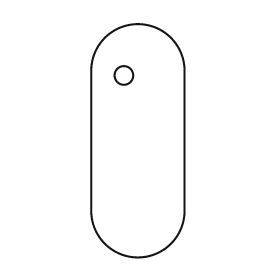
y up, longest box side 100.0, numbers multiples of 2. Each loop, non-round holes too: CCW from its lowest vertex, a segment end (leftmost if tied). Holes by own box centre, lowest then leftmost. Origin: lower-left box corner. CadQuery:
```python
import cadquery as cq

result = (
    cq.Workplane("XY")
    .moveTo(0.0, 20.0)
    .threePointArc((20.0, 0.0), (40.0, 20.0))
    .lineTo(40.0, 80.0)
    .threePointArc((20.0, 100.0), (0.0, 80.0))
    .close()
    .moveTo(14.0, 78.0)
    .circle(4.0)
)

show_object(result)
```